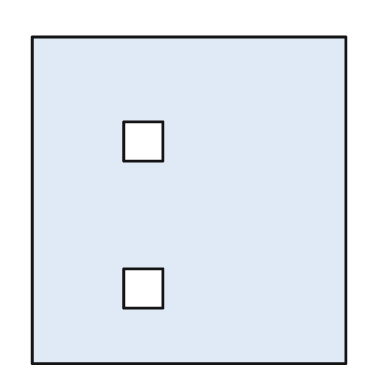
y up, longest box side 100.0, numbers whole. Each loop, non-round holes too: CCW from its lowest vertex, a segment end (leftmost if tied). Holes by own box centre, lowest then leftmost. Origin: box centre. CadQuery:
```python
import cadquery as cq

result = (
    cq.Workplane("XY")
    .moveTo(-48.0, -50.0)
    .lineTo(48.0, -50.0)
    .lineTo(48.0, 50.0)
    .lineTo(-48.0, 50.0)
    .close()
    .moveTo(-20.0, -33.0)
    .lineTo(-8.0, -33.0)
    .lineTo(-8.0, -21.0)
    .lineTo(-20.0, -21.0)
    .close()
    .moveTo(-20.0, 12.0)
    .lineTo(-8.0, 12.0)
    .lineTo(-8.0, 24.0)
    .lineTo(-20.0, 24.0)
    .close()
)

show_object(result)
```